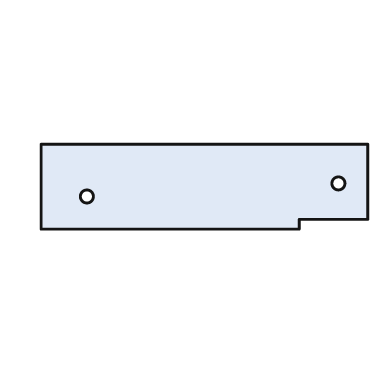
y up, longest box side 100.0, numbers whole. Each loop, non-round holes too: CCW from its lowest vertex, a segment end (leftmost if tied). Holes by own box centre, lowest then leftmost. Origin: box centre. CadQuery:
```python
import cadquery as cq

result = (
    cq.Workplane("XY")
    .moveTo(-50.0, -13.0)
    .lineTo(29.0, -13.0)
    .lineTo(29.0, -10.0)
    .lineTo(50.0, -10.0)
    .lineTo(50.0, 13.0)
    .lineTo(-50.0, 13.0)
    .close()
    .moveTo(-36.0, -3.0)
    .circle(2.0)
    .moveTo(41.0, 1.0)
    .circle(2.0)
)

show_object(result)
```